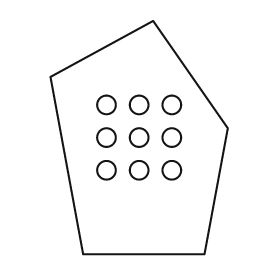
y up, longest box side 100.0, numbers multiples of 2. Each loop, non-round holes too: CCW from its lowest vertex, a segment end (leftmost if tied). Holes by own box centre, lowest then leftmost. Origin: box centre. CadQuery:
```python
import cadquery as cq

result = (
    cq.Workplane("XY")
    .moveTo(-24.0, -50.0)
    .lineTo(28.0, -50.0)
    .lineTo(38.0, 4.0)
    .lineTo(6.0, 50.0)
    .lineTo(-38.0, 26.0)
    .close()
    .moveTo(-14.0, -14.0)
    .circle(4.0)
    .moveTo(0.0, -14.0)
    .circle(4.0)
    .moveTo(14.0, -14.0)
    .circle(4.0)
    .moveTo(-14.0, 0.0)
    .circle(4.0)
    .moveTo(0.0, 0.0)
    .circle(4.0)
    .moveTo(14.0, 0.0)
    .circle(4.0)
    .moveTo(-14.0, 14.0)
    .circle(4.0)
    .moveTo(0.0, 14.0)
    .circle(4.0)
    .moveTo(14.0, 14.0)
    .circle(4.0)
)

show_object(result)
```